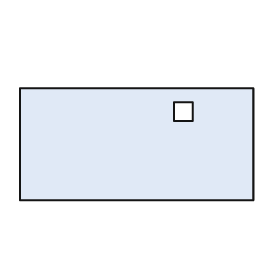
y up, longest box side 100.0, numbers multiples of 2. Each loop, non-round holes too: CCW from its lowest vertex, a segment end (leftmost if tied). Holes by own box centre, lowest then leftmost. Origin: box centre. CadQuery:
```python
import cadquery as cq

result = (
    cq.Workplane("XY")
    .moveTo(-50.0, -24.0)
    .lineTo(50.0, -24.0)
    .lineTo(50.0, 24.0)
    .lineTo(-50.0, 24.0)
    .close()
    .moveTo(16.0, 10.0)
    .lineTo(24.0, 10.0)
    .lineTo(24.0, 18.0)
    .lineTo(16.0, 18.0)
    .close()
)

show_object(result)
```